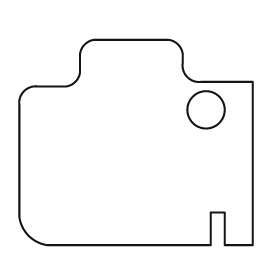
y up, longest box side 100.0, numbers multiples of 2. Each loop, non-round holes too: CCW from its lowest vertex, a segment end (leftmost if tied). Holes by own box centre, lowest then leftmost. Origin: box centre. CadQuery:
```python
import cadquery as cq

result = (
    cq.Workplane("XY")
    .moveTo(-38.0, -44.0)
    .lineTo(32.0, -44.0)
    .lineTo(32.0, -30.0)
    .lineTo(38.0, -30.0)
    .lineTo(38.0, -44.0)
    .lineTo(50.0, -44.0)
    .lineTo(50.0, 26.0)
    .lineTo(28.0, 26.0)
    .threePointArc((22.0, 28.0), (20.0, 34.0))
    .lineTo(20.0, 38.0)
    .threePointArc((18.0, 42.0), (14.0, 44.0))
    .lineTo(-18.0, 44.0)
    .threePointArc((-22.0, 42.0), (-24.0, 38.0))
    .lineTo(-24.0, 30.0)
    .threePointArc((-26.0, 26.0), (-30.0, 24.0))
    .lineTo(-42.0, 24.0)
    .threePointArc((-48.0, 22.0), (-50.0, 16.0))
    .lineTo(-50.0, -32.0)
    .threePointArc((-46.0, -40.0), (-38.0, -44.0))
    .close()
    .moveTo(30.0, 14.0)
    .circle(8.0)
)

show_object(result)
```